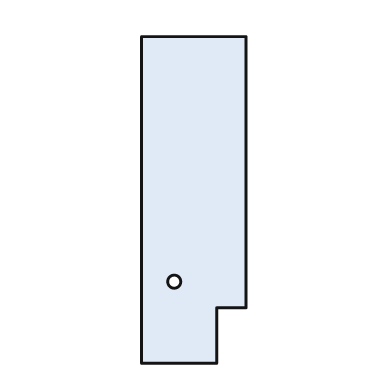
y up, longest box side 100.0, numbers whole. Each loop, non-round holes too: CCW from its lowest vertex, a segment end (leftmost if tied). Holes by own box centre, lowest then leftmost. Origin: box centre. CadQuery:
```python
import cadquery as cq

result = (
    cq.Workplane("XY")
    .moveTo(-16.0, -50.0)
    .lineTo(7.0, -50.0)
    .lineTo(7.0, -33.0)
    .lineTo(16.0, -33.0)
    .lineTo(16.0, 50.0)
    .lineTo(-16.0, 50.0)
    .close()
    .moveTo(-6.0, -25.0)
    .circle(2.0)
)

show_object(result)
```